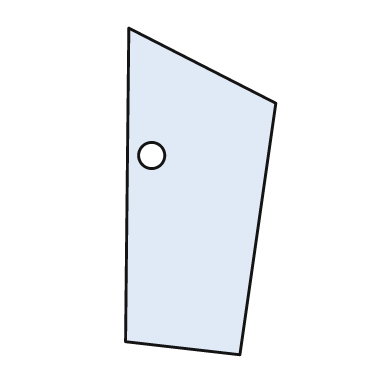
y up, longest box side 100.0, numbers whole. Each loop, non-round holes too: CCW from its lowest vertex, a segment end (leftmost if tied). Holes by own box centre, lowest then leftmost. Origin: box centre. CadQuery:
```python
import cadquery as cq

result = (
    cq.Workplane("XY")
    .moveTo(12.0, -50.0)
    .lineTo(23.0, 27.0)
    .lineTo(-22.0, 50.0)
    .lineTo(-23.0, -46.0)
    .close()
    .moveTo(-15.0, 11.0)
    .circle(4.0)
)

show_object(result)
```